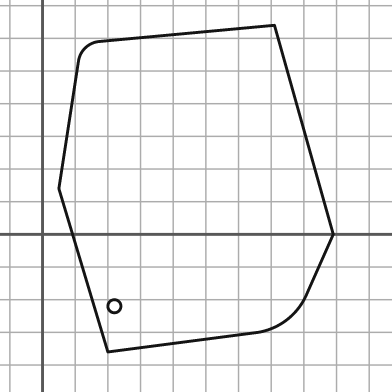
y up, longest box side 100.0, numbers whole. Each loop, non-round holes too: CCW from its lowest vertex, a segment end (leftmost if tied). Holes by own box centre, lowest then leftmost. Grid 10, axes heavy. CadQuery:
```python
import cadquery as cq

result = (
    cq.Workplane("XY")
    .moveTo(20.0, -36.0)
    .lineTo(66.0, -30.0)
    .threePointArc((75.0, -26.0), (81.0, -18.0))
    .lineTo(89.0, 0.0)
    .lineTo(71.0, 64.0)
    .lineTo(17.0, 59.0)
    .threePointArc((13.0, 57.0), (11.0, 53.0))
    .lineTo(5.0, 14.0)
    .close()
    .moveTo(22.0, -22.0)
    .circle(2.0)
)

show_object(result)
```